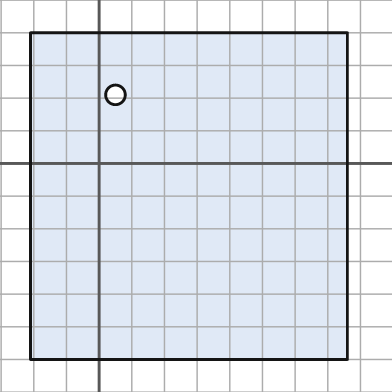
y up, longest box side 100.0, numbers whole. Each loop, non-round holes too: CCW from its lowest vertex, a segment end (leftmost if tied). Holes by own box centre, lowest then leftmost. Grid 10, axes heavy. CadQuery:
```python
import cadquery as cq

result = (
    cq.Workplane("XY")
    .moveTo(-21.0, -60.0)
    .lineTo(76.0, -60.0)
    .lineTo(76.0, 40.0)
    .lineTo(-21.0, 40.0)
    .close()
    .moveTo(5.0, 21.0)
    .circle(3.0)
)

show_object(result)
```